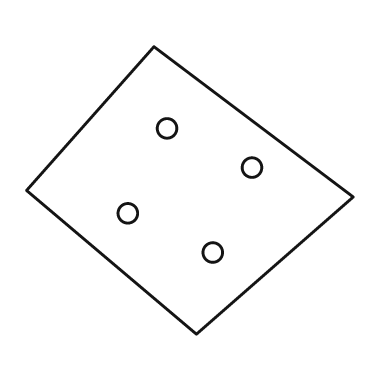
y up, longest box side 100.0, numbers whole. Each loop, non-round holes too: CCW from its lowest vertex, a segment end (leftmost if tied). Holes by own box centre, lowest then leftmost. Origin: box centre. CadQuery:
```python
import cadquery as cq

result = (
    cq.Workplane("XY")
    .moveTo(2.0, -44.0)
    .lineTo(50.0, -2.0)
    .lineTo(-11.0, 44.0)
    .lineTo(-50.0, 0.0)
    .close()
    .moveTo(7.0, -19.0)
    .circle(3.0)
    .moveTo(-19.0, -7.0)
    .circle(3.0)
    .moveTo(19.0, 7.0)
    .circle(3.0)
    .moveTo(-7.0, 19.0)
    .circle(3.0)
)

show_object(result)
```